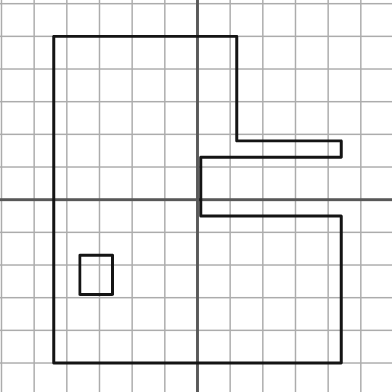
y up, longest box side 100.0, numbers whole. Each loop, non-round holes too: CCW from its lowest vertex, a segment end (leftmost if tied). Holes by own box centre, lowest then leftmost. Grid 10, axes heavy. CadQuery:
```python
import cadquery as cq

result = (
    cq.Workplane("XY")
    .moveTo(-44.0, -50.0)
    .lineTo(44.0, -50.0)
    .lineTo(44.0, -5.0)
    .lineTo(1.0, -5.0)
    .lineTo(1.0, 13.0)
    .lineTo(44.0, 13.0)
    .lineTo(44.0, 18.0)
    .lineTo(12.0, 18.0)
    .lineTo(12.0, 50.0)
    .lineTo(-44.0, 50.0)
    .close()
    .moveTo(-36.0, -29.0)
    .lineTo(-26.0, -29.0)
    .lineTo(-26.0, -17.0)
    .lineTo(-36.0, -17.0)
    .close()
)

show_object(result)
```